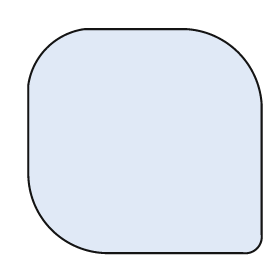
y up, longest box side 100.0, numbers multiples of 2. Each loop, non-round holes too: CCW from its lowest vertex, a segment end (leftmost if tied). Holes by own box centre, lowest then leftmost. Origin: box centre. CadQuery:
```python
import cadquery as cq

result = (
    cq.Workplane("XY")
    .moveTo(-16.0, -48.0)
    .lineTo(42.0, -48.0)
    .threePointArc((48.0, -46.0), (50.0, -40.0))
    .lineTo(50.0, 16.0)
    .threePointArc((40.0, 38.0), (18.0, 48.0))
    .lineTo(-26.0, 48.0)
    .threePointArc((-42.0, 40.0), (-50.0, 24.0))
    .lineTo(-50.0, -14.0)
    .threePointArc((-40.0, -38.0), (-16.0, -48.0))
    .close()
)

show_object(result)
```